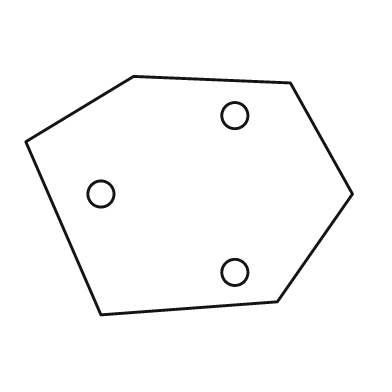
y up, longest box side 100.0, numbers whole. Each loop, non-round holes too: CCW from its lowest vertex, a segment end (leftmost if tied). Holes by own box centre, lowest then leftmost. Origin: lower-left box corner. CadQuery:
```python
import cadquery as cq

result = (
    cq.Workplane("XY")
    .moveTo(23.0, 0.0)
    .lineTo(77.0, 4.0)
    .lineTo(100.0, 37.0)
    .lineTo(81.0, 71.0)
    .lineTo(33.0, 73.0)
    .lineTo(0.0, 53.0)
    .close()
    .moveTo(64.0, 13.0)
    .circle(4.0)
    .moveTo(23.0, 37.0)
    .circle(4.0)
    .moveTo(64.0, 61.0)
    .circle(4.0)
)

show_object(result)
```